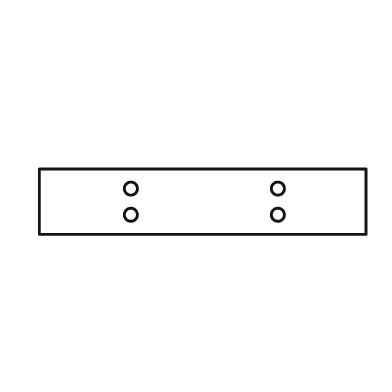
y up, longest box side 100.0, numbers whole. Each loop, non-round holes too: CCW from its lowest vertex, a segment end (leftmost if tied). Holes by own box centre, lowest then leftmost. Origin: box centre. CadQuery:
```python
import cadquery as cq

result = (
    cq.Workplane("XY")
    .moveTo(-50.0, -10.0)
    .lineTo(50.0, -10.0)
    .lineTo(50.0, 10.0)
    .lineTo(-50.0, 10.0)
    .close()
    .moveTo(-22.0, -4.0)
    .circle(2.0)
    .moveTo(23.0, -4.0)
    .circle(2.0)
    .moveTo(-22.0, 4.0)
    .circle(2.0)
    .moveTo(23.0, 4.0)
    .circle(2.0)
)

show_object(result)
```